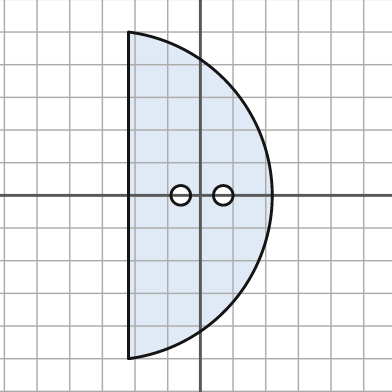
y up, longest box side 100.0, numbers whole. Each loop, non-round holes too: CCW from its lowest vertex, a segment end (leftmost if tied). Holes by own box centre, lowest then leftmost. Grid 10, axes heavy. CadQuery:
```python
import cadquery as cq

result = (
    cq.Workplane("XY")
    .moveTo(-22.0, -50.0)
    .threePointArc((22.0, 0.0), (-22.0, 50.0))
    .close()
    .moveTo(-6.0, 0.0)
    .circle(3.0)
    .moveTo(7.0, 0.0)
    .circle(3.0)
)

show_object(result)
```